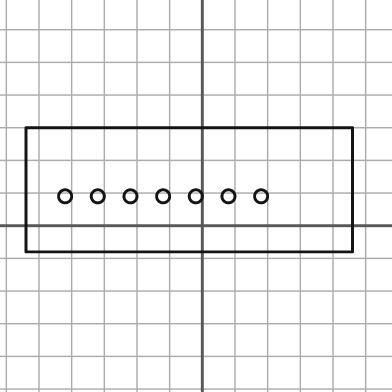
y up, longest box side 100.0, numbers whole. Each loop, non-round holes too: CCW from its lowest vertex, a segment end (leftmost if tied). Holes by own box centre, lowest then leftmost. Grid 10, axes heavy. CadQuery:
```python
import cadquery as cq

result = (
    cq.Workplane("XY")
    .moveTo(-54.0, -8.0)
    .lineTo(46.0, -8.0)
    .lineTo(46.0, 30.0)
    .lineTo(-54.0, 30.0)
    .close()
    .moveTo(-42.0, 9.0)
    .circle(2.0)
    .moveTo(-32.0, 9.0)
    .circle(2.0)
    .moveTo(-22.0, 9.0)
    .circle(2.0)
    .moveTo(-12.0, 9.0)
    .circle(2.0)
    .moveTo(-2.0, 9.0)
    .circle(2.0)
    .moveTo(8.0, 9.0)
    .circle(2.0)
    .moveTo(18.0, 9.0)
    .circle(2.0)
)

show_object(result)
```